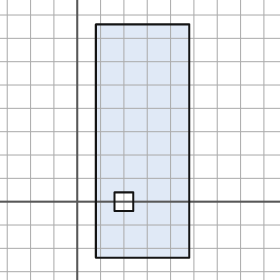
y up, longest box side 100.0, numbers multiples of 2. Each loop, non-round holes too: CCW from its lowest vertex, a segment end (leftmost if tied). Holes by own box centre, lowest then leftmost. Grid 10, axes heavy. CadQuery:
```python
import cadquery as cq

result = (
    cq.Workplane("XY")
    .moveTo(8.0, -24.0)
    .lineTo(48.0, -24.0)
    .lineTo(48.0, 76.0)
    .lineTo(8.0, 76.0)
    .close()
    .moveTo(16.0, -4.0)
    .lineTo(24.0, -4.0)
    .lineTo(24.0, 4.0)
    .lineTo(16.0, 4.0)
    .close()
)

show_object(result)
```